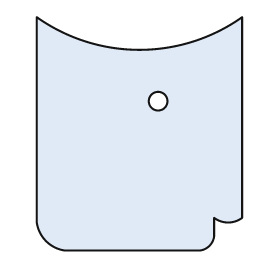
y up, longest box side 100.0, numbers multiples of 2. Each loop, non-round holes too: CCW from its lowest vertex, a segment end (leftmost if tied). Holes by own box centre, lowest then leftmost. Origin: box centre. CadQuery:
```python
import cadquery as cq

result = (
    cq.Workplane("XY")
    .moveTo(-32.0, -50.0)
    .lineTo(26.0, -50.0)
    .threePointArc((30.0, -48.0), (32.0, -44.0))
    .lineTo(32.0, -36.0)
    .threePointArc((38.0, -38.0), (44.0, -36.0))
    .lineTo(44.0, 50.0)
    .threePointArc((0.0, 36.0), (-44.0, 50.0))
    .lineTo(-44.0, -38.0)
    .threePointArc((-40.0, -46.0), (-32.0, -50.0))
    .close()
    .moveTo(8.0, 14.0)
    .circle(4.0)
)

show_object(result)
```